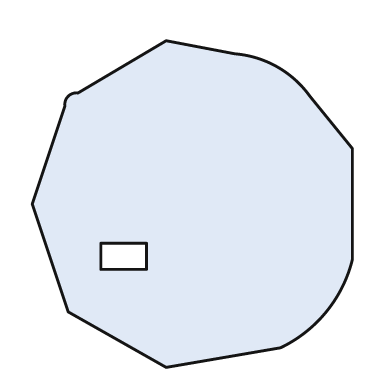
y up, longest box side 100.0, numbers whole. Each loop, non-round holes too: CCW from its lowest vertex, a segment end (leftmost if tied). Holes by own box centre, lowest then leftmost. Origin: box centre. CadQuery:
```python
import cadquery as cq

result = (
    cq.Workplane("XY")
    .moveTo(-8.0, -50.0)
    .lineTo(27.0, -44.0)
    .threePointArc((41.0, -33.0), (49.0, -17.0))
    .lineTo(49.0, 17.0)
    .lineTo(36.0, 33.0)
    .threePointArc((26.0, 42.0), (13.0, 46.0))
    .lineTo(-8.0, 50.0)
    .lineTo(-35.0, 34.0)
    .threePointArc((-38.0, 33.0), (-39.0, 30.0))
    .lineTo(-49.0, 0.0)
    .lineTo(-38.0, -33.0)
    .close()
    .moveTo(-28.0, -20.0)
    .lineTo(-14.0, -20.0)
    .lineTo(-14.0, -12.0)
    .lineTo(-28.0, -12.0)
    .close()
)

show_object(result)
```